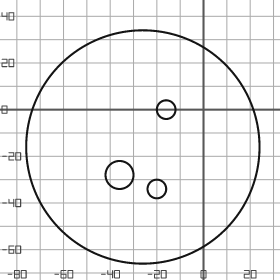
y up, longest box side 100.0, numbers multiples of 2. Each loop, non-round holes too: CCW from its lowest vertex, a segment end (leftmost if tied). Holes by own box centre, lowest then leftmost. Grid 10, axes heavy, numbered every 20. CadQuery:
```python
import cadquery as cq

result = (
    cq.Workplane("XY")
    .moveTo(-26.0, -16.0)
    .circle(50.0)
    .moveTo(-20.0, -34.0)
    .circle(4.0)
    .moveTo(-36.0, -28.0)
    .circle(6.0)
    .moveTo(-16.0, 0.0)
    .circle(4.0)
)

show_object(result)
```